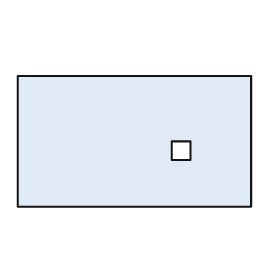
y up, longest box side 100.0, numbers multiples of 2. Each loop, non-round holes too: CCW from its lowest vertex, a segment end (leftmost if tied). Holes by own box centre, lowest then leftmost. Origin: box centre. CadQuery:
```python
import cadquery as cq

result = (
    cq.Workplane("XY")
    .moveTo(-50.0, -28.0)
    .lineTo(50.0, -28.0)
    .lineTo(50.0, 28.0)
    .lineTo(-50.0, 28.0)
    .close()
    .moveTo(16.0, -8.0)
    .lineTo(24.0, -8.0)
    .lineTo(24.0, 0.0)
    .lineTo(16.0, 0.0)
    .close()
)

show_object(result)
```